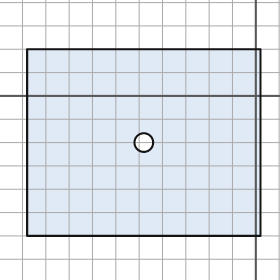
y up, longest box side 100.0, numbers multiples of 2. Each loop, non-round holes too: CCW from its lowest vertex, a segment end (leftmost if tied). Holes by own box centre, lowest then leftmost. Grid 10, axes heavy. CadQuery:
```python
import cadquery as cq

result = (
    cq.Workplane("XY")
    .moveTo(-98.0, -60.0)
    .lineTo(2.0, -60.0)
    .lineTo(2.0, 20.0)
    .lineTo(-98.0, 20.0)
    .close()
    .moveTo(-48.0, -20.0)
    .circle(4.0)
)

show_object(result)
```